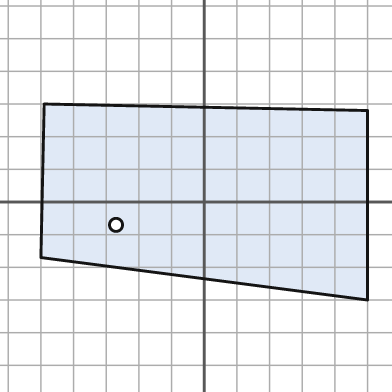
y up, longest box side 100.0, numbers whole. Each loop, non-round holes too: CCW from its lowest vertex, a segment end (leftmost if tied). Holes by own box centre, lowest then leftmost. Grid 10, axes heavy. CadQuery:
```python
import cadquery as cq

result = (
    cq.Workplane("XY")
    .moveTo(50.0, -30.0)
    .lineTo(50.0, 28.0)
    .lineTo(-49.0, 30.0)
    .lineTo(-50.0, -17.0)
    .close()
    .moveTo(-27.0, -7.0)
    .circle(2.0)
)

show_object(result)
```